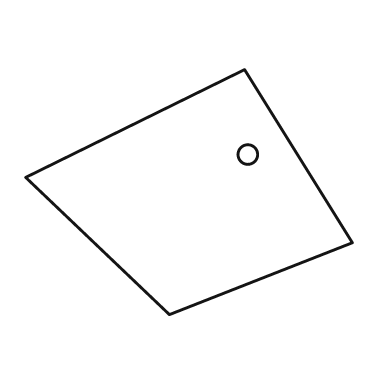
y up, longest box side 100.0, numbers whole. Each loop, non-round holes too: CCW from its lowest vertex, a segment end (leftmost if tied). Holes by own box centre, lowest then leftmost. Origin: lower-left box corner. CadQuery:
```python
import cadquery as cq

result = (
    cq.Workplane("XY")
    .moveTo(44.0, 0.0)
    .lineTo(100.0, 22.0)
    .lineTo(67.0, 75.0)
    .lineTo(0.0, 42.0)
    .close()
    .moveTo(68.0, 49.0)
    .circle(3.0)
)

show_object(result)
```